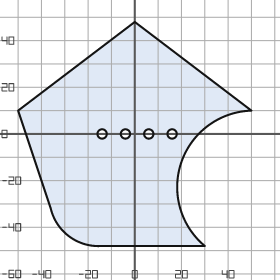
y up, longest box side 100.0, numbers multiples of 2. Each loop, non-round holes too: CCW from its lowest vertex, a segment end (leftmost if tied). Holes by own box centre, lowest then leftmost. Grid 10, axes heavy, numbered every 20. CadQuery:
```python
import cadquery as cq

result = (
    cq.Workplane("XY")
    .moveTo(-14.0, -48.0)
    .lineTo(30.0, -48.0)
    .threePointArc((20.0, -12.0), (50.0, 10.0))
    .lineTo(0.0, 48.0)
    .lineTo(-50.0, 10.0)
    .lineTo(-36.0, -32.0)
    .threePointArc((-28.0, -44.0), (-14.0, -48.0))
    .close()
    .moveTo(-14.0, 0.0)
    .circle(2.0)
    .moveTo(-4.0, 0.0)
    .circle(2.0)
    .moveTo(6.0, 0.0)
    .circle(2.0)
    .moveTo(16.0, 0.0)
    .circle(2.0)
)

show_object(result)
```